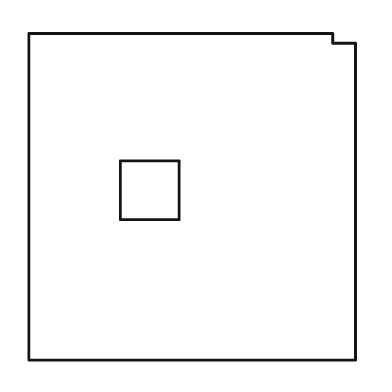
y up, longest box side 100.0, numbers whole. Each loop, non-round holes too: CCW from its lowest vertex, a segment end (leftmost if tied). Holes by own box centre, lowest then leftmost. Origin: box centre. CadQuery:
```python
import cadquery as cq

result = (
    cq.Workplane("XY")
    .moveTo(-50.0, -50.0)
    .lineTo(50.0, -50.0)
    .lineTo(50.0, 47.0)
    .lineTo(43.0, 47.0)
    .lineTo(43.0, 50.0)
    .lineTo(-50.0, 50.0)
    .close()
    .moveTo(-22.0, -7.0)
    .lineTo(-4.0, -7.0)
    .lineTo(-4.0, 11.0)
    .lineTo(-22.0, 11.0)
    .close()
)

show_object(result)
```